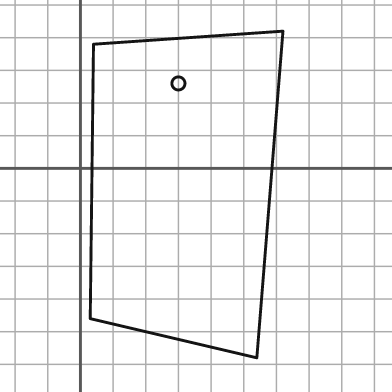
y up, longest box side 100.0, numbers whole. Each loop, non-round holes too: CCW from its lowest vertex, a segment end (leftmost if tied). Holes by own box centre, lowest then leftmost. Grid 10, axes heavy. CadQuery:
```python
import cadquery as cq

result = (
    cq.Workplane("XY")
    .moveTo(54.0, -58.0)
    .lineTo(62.0, 42.0)
    .lineTo(4.0, 38.0)
    .lineTo(3.0, -46.0)
    .close()
    .moveTo(30.0, 26.0)
    .circle(2.0)
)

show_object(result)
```